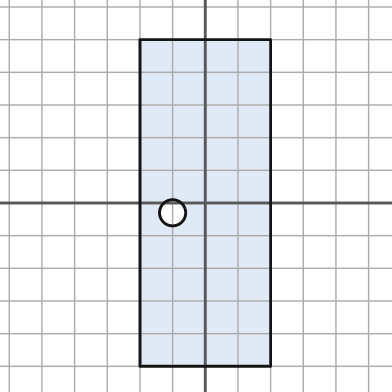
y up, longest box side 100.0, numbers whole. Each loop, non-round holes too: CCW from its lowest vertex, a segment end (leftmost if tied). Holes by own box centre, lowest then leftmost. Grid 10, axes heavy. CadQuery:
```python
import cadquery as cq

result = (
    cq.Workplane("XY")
    .moveTo(-20.0, -50.0)
    .lineTo(20.0, -50.0)
    .lineTo(20.0, 50.0)
    .lineTo(-20.0, 50.0)
    .close()
    .moveTo(-10.0, -3.0)
    .circle(4.0)
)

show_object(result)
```